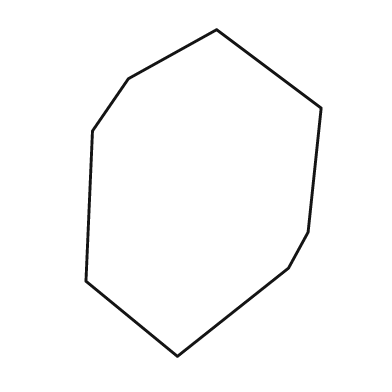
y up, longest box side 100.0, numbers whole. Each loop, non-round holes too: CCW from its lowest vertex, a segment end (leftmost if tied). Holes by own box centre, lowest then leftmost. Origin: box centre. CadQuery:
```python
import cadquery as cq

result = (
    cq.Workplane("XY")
    .moveTo(-8.0, -50.0)
    .lineTo(26.0, -23.0)
    .lineTo(32.0, -12.0)
    .lineTo(36.0, 26.0)
    .lineTo(4.0, 50.0)
    .lineTo(-23.0, 35.0)
    .lineTo(-34.0, 19.0)
    .lineTo(-36.0, -27.0)
    .close()
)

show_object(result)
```